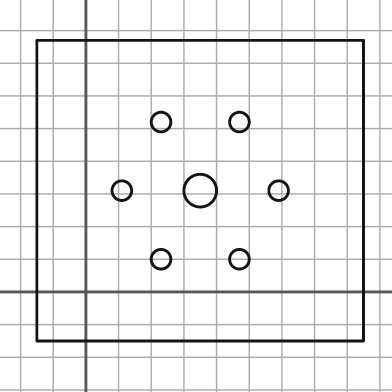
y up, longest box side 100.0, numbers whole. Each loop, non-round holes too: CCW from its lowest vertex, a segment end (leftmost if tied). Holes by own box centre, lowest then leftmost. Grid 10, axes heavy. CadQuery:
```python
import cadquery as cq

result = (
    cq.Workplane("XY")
    .moveTo(-15.0, -15.0)
    .lineTo(85.0, -15.0)
    .lineTo(85.0, 77.0)
    .lineTo(-15.0, 77.0)
    .close()
    .moveTo(23.0, 10.0)
    .circle(3.0)
    .moveTo(47.0, 10.0)
    .circle(3.0)
    .moveTo(11.0, 31.0)
    .circle(3.0)
    .moveTo(35.0, 31.0)
    .circle(5.0)
    .moveTo(59.0, 31.0)
    .circle(3.0)
    .moveTo(23.0, 52.0)
    .circle(3.0)
    .moveTo(47.0, 52.0)
    .circle(3.0)
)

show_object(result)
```